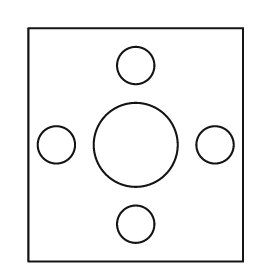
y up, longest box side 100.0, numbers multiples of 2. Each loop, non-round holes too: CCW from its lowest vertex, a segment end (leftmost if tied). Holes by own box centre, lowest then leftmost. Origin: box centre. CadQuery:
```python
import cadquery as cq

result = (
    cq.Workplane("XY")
    .moveTo(-46.0, -50.0)
    .lineTo(46.0, -50.0)
    .lineTo(46.0, 50.0)
    .lineTo(-46.0, 50.0)
    .close()
    .moveTo(0.0, -34.0)
    .circle(8.0)
    .moveTo(-34.0, 0.0)
    .circle(8.0)
    .moveTo(0.0, 0.0)
    .circle(18.0)
    .moveTo(34.0, 0.0)
    .circle(8.0)
    .moveTo(0.0, 34.0)
    .circle(8.0)
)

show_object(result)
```